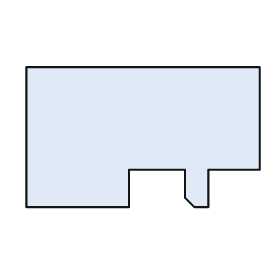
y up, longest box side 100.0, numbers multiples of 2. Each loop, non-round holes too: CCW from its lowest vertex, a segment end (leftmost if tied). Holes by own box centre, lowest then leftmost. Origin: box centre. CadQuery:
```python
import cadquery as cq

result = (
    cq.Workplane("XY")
    .moveTo(-50.0, -30.0)
    .lineTo(-6.0, -30.0)
    .lineTo(-6.0, -14.0)
    .lineTo(18.0, -14.0)
    .lineTo(18.0, -26.0)
    .lineTo(22.0, -30.0)
    .lineTo(28.0, -30.0)
    .lineTo(28.0, -14.0)
    .lineTo(50.0, -14.0)
    .lineTo(50.0, 30.0)
    .lineTo(-50.0, 30.0)
    .close()
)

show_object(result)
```